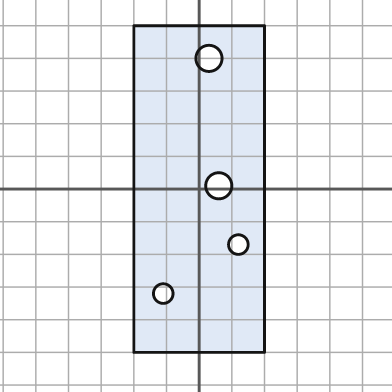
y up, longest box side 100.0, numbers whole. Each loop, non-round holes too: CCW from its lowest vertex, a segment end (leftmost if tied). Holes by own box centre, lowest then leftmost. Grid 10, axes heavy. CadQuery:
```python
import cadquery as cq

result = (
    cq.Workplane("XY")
    .moveTo(-20.0, -50.0)
    .lineTo(20.0, -50.0)
    .lineTo(20.0, 50.0)
    .lineTo(-20.0, 50.0)
    .close()
    .moveTo(-11.0, -32.0)
    .circle(3.0)
    .moveTo(12.0, -17.0)
    .circle(3.0)
    .moveTo(6.0, 1.0)
    .circle(4.0)
    .moveTo(3.0, 40.0)
    .circle(4.0)
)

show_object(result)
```